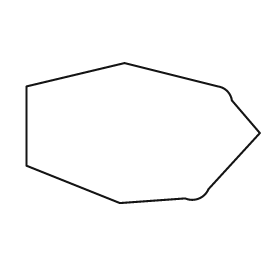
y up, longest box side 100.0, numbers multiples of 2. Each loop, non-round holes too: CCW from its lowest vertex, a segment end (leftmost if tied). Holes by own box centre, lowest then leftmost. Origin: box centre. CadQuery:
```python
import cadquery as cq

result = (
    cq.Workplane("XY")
    .moveTo(-10.0, -30.0)
    .lineTo(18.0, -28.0)
    .threePointArc((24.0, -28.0), (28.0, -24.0))
    .lineTo(50.0, 0.0)
    .lineTo(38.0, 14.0)
    .threePointArc((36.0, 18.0), (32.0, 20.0))
    .lineTo(-8.0, 30.0)
    .lineTo(-50.0, 20.0)
    .lineTo(-50.0, -14.0)
    .close()
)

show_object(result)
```